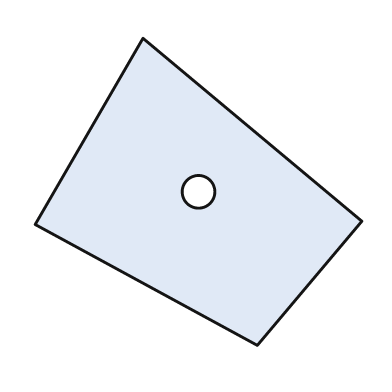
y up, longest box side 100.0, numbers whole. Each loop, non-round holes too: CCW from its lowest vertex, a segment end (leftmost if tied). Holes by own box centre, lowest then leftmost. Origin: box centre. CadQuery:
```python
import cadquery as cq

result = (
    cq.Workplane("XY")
    .moveTo(18.0, -47.0)
    .lineTo(50.0, -9.0)
    .lineTo(-17.0, 47.0)
    .lineTo(-50.0, -10.0)
    .close()
    .moveTo(0.0, 0.0)
    .circle(5.0)
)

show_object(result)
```